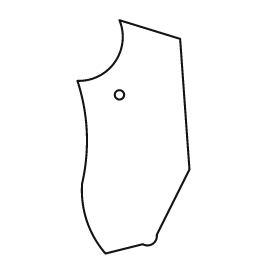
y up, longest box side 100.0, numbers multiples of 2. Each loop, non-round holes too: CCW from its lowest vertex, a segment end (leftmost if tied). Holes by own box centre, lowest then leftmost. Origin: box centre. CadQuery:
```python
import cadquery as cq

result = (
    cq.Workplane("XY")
    .moveTo(-12.0, -50.0)
    .lineTo(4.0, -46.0)
    .threePointArc((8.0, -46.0), (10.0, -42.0))
    .lineTo(24.0, -14.0)
    .lineTo(20.0, 42.0)
    .lineTo(-6.0, 50.0)
    .threePointArc((-8.0, 32.0), (-24.0, 24.0))
    .threePointArc((-20.0, 2.0), (-22.0, -20.0))
    .threePointArc((-20.0, -36.0), (-12.0, -50.0))
    .close()
    .moveTo(-6.0, 18.0)
    .circle(2.0)
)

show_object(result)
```